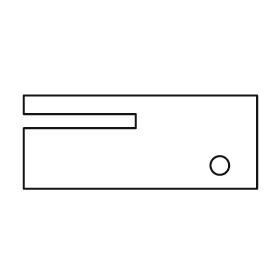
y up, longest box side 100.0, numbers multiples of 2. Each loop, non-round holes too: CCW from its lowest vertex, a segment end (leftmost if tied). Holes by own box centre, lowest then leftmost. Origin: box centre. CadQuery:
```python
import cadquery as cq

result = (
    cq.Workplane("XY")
    .moveTo(-50.0, -20.0)
    .lineTo(50.0, -20.0)
    .lineTo(50.0, 20.0)
    .lineTo(-50.0, 20.0)
    .lineTo(-50.0, 12.0)
    .lineTo(-2.0, 12.0)
    .lineTo(-2.0, 6.0)
    .lineTo(-50.0, 6.0)
    .close()
    .moveTo(34.0, -10.0)
    .circle(4.0)
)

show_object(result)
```